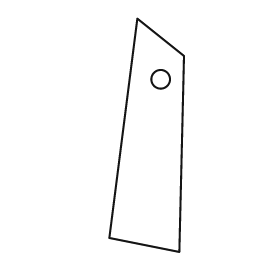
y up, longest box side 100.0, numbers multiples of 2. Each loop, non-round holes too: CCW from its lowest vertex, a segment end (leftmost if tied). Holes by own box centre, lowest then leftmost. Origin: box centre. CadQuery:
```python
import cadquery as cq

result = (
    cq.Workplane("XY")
    .moveTo(14.0, -50.0)
    .lineTo(16.0, 34.0)
    .lineTo(-4.0, 50.0)
    .lineTo(-16.0, -44.0)
    .close()
    .moveTo(6.0, 24.0)
    .circle(4.0)
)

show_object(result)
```